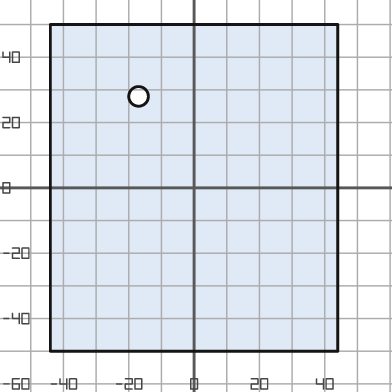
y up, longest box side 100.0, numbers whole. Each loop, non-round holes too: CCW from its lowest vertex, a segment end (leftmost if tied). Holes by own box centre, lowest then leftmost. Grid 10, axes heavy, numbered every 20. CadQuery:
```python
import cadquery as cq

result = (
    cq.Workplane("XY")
    .moveTo(-44.0, -50.0)
    .lineTo(44.0, -50.0)
    .lineTo(44.0, 50.0)
    .lineTo(-44.0, 50.0)
    .close()
    .moveTo(-17.0, 28.0)
    .circle(3.0)
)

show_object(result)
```